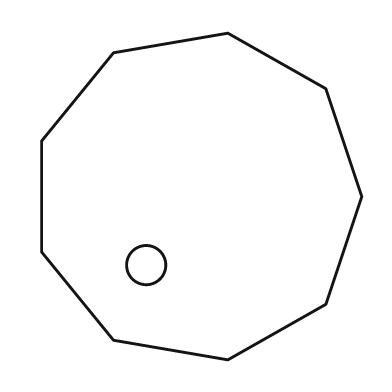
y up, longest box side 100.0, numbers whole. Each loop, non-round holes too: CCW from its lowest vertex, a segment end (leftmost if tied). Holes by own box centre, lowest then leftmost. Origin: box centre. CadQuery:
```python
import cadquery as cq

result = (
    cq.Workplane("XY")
    .moveTo(8.0, -50.0)
    .lineTo(38.0, -33.0)
    .lineTo(49.0, 0.0)
    .lineTo(38.0, 33.0)
    .lineTo(8.0, 50.0)
    .lineTo(-27.0, 44.0)
    .lineTo(-49.0, 17.0)
    .lineTo(-49.0, -17.0)
    .lineTo(-27.0, -44.0)
    .close()
    .moveTo(-17.0, -21.0)
    .circle(6.0)
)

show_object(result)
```